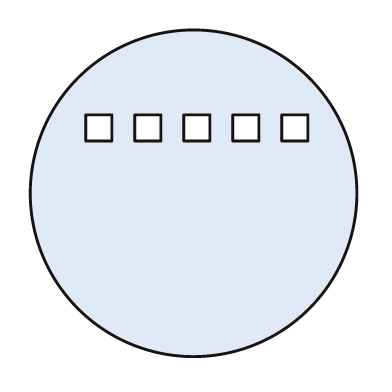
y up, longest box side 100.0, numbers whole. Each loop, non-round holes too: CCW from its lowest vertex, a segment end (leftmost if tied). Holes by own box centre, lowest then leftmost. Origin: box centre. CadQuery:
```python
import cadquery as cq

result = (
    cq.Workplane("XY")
    .moveTo(0.0, 0.0)
    .circle(50.0)
    .moveTo(-33.0, 16.0)
    .lineTo(-25.0, 16.0)
    .lineTo(-25.0, 24.0)
    .lineTo(-33.0, 24.0)
    .close()
    .moveTo(-18.0, 16.0)
    .lineTo(-10.0, 16.0)
    .lineTo(-10.0, 24.0)
    .lineTo(-18.0, 24.0)
    .close()
    .moveTo(-3.0, 16.0)
    .lineTo(5.0, 16.0)
    .lineTo(5.0, 24.0)
    .lineTo(-3.0, 24.0)
    .close()
    .moveTo(12.0, 16.0)
    .lineTo(20.0, 16.0)
    .lineTo(20.0, 24.0)
    .lineTo(12.0, 24.0)
    .close()
    .moveTo(27.0, 16.0)
    .lineTo(35.0, 16.0)
    .lineTo(35.0, 24.0)
    .lineTo(27.0, 24.0)
    .close()
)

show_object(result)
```